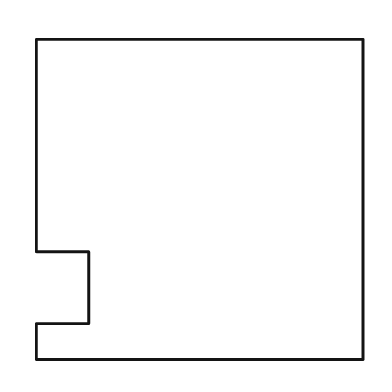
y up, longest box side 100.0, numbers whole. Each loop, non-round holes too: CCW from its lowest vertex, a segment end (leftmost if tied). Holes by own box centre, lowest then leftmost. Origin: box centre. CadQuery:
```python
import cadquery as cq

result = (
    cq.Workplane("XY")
    .moveTo(-50.0, -49.0)
    .lineTo(50.0, -49.0)
    .lineTo(50.0, 49.0)
    .lineTo(-50.0, 49.0)
    .lineTo(-50.0, -16.0)
    .lineTo(-34.0, -16.0)
    .lineTo(-34.0, -38.0)
    .lineTo(-50.0, -38.0)
    .close()
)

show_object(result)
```